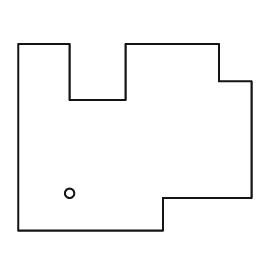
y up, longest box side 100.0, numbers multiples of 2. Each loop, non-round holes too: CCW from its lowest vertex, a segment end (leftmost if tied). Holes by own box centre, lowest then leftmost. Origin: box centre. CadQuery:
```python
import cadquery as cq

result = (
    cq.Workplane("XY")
    .moveTo(-50.0, -40.0)
    .lineTo(12.0, -40.0)
    .lineTo(12.0, -26.0)
    .lineTo(50.0, -26.0)
    .lineTo(50.0, 24.0)
    .lineTo(36.0, 24.0)
    .lineTo(36.0, 40.0)
    .lineTo(-4.0, 40.0)
    .lineTo(-4.0, 16.0)
    .lineTo(-28.0, 16.0)
    .lineTo(-28.0, 40.0)
    .lineTo(-50.0, 40.0)
    .close()
    .moveTo(-28.0, -24.0)
    .circle(2.0)
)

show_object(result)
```